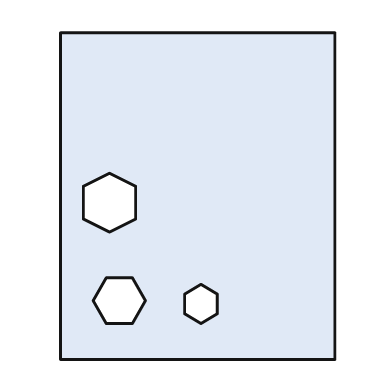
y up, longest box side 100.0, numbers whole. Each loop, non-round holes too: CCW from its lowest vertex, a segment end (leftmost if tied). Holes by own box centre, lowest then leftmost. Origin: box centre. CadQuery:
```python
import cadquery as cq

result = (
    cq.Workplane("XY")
    .moveTo(-42.0, -50.0)
    .lineTo(42.0, -50.0)
    .lineTo(42.0, 50.0)
    .lineTo(-42.0, 50.0)
    .close()
    .moveTo(1.0, -39.0)
    .lineTo(6.0, -36.0)
    .lineTo(6.0, -30.0)
    .lineTo(1.0, -27.0)
    .lineTo(-4.0, -30.0)
    .lineTo(-4.0, -36.0)
    .close()
    .moveTo(-28.0, -39.0)
    .lineTo(-20.0, -39.0)
    .lineTo(-16.0, -32.0)
    .lineTo(-20.0, -25.0)
    .lineTo(-28.0, -25.0)
    .lineTo(-32.0, -32.0)
    .close()
    .moveTo(-27.0, -11.0)
    .lineTo(-19.0, -7.0)
    .lineTo(-19.0, 3.0)
    .lineTo(-27.0, 7.0)
    .lineTo(-35.0, 3.0)
    .lineTo(-35.0, -7.0)
    .close()
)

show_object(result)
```